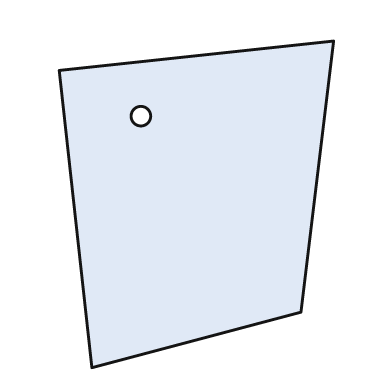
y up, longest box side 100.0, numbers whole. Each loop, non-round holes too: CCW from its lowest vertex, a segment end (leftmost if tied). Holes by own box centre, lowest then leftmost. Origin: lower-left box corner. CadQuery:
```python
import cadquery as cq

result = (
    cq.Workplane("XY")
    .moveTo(10.0, 0.0)
    .lineTo(74.0, 17.0)
    .lineTo(84.0, 100.0)
    .lineTo(0.0, 91.0)
    .close()
    .moveTo(25.0, 77.0)
    .circle(3.0)
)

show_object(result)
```